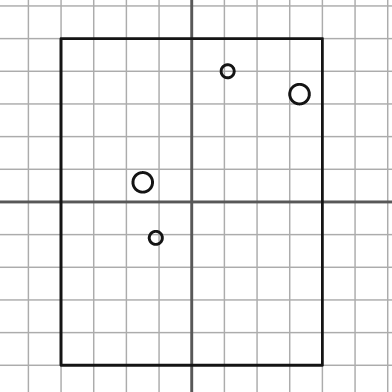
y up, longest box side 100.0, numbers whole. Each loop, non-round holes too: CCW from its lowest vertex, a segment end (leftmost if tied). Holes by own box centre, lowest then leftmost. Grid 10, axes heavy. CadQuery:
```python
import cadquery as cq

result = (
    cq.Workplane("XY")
    .moveTo(-40.0, -50.0)
    .lineTo(40.0, -50.0)
    .lineTo(40.0, 50.0)
    .lineTo(-40.0, 50.0)
    .close()
    .moveTo(-11.0, -11.0)
    .circle(2.0)
    .moveTo(-15.0, 6.0)
    .circle(3.0)
    .moveTo(33.0, 33.0)
    .circle(3.0)
    .moveTo(11.0, 40.0)
    .circle(2.0)
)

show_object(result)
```